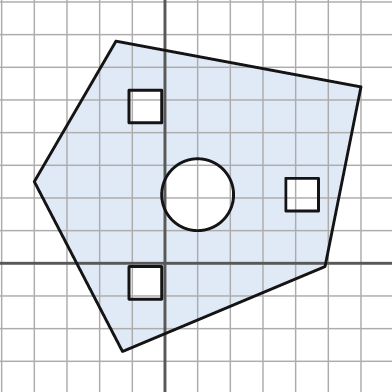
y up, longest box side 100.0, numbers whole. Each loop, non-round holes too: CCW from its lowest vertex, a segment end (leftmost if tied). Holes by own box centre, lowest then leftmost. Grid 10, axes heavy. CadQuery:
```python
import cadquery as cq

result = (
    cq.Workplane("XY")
    .moveTo(-13.0, -27.0)
    .lineTo(49.0, -1.0)
    .lineTo(60.0, 54.0)
    .lineTo(-15.0, 68.0)
    .lineTo(-40.0, 25.0)
    .close()
    .moveTo(-11.0, -11.0)
    .lineTo(-1.0, -11.0)
    .lineTo(-1.0, -1.0)
    .lineTo(-11.0, -1.0)
    .close()
    .moveTo(10.0, 21.0)
    .circle(11.0)
    .moveTo(37.0, 16.0)
    .lineTo(47.0, 16.0)
    .lineTo(47.0, 26.0)
    .lineTo(37.0, 26.0)
    .close()
    .moveTo(-11.0, 43.0)
    .lineTo(-1.0, 43.0)
    .lineTo(-1.0, 53.0)
    .lineTo(-11.0, 53.0)
    .close()
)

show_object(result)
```